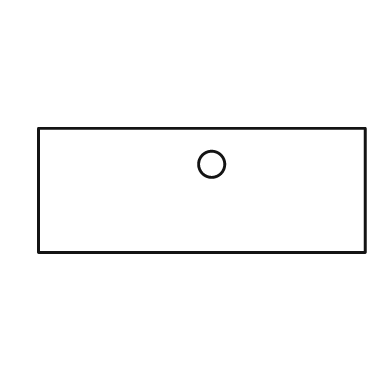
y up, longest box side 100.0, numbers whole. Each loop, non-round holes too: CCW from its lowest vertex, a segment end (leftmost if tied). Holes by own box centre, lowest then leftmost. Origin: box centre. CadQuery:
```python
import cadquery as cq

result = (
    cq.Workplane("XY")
    .moveTo(-50.0, -19.0)
    .lineTo(50.0, -19.0)
    .lineTo(50.0, 19.0)
    .lineTo(-50.0, 19.0)
    .close()
    .moveTo(3.0, 8.0)
    .circle(4.0)
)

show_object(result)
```